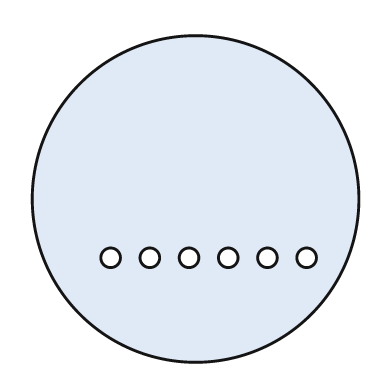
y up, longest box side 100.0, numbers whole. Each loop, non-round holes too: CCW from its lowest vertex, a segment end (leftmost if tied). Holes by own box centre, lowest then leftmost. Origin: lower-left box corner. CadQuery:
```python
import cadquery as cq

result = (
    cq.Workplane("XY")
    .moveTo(50.0, 50.0)
    .circle(50.0)
    .moveTo(24.0, 32.0)
    .circle(3.0)
    .moveTo(36.0, 32.0)
    .circle(3.0)
    .moveTo(48.0, 32.0)
    .circle(3.0)
    .moveTo(60.0, 32.0)
    .circle(3.0)
    .moveTo(72.0, 32.0)
    .circle(3.0)
    .moveTo(84.0, 32.0)
    .circle(3.0)
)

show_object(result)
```